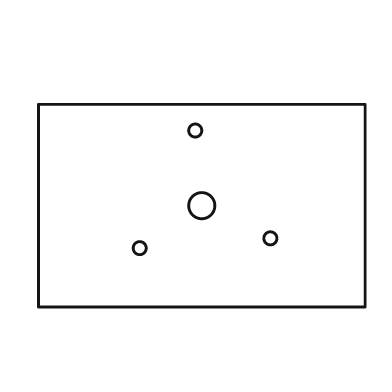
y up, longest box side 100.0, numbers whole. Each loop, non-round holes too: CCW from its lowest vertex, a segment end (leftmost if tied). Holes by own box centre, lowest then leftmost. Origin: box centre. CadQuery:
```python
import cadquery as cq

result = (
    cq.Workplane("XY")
    .moveTo(-50.0, -31.0)
    .lineTo(50.0, -31.0)
    .lineTo(50.0, 31.0)
    .lineTo(-50.0, 31.0)
    .close()
    .moveTo(-19.0, -13.0)
    .circle(2.0)
    .moveTo(21.0, -10.0)
    .circle(2.0)
    .moveTo(0.0, 0.0)
    .circle(4.0)
    .moveTo(-2.0, 23.0)
    .circle(2.0)
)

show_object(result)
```